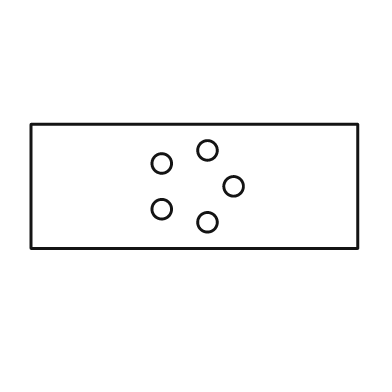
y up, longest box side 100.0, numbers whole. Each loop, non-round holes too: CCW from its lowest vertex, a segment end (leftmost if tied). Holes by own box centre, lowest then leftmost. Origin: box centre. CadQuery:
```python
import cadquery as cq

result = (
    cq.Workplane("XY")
    .moveTo(-50.0, -19.0)
    .lineTo(50.0, -19.0)
    .lineTo(50.0, 19.0)
    .lineTo(-50.0, 19.0)
    .close()
    .moveTo(4.0, -11.0)
    .circle(3.0)
    .moveTo(-10.0, -7.0)
    .circle(3.0)
    .moveTo(12.0, 0.0)
    .circle(3.0)
    .moveTo(-10.0, 7.0)
    .circle(3.0)
    .moveTo(4.0, 11.0)
    .circle(3.0)
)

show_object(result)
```